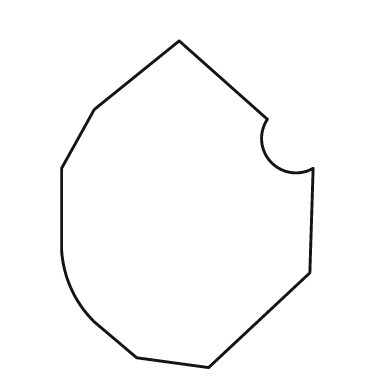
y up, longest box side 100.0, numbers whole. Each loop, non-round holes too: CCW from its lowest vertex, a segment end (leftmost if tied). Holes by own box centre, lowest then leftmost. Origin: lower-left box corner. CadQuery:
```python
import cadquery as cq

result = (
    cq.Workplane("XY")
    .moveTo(45.0, 0.0)
    .lineTo(76.0, 29.0)
    .lineTo(77.0, 61.0)
    .threePointArc((64.0, 63.0), (63.0, 76.0))
    .lineTo(36.0, 100.0)
    .lineTo(10.0, 79.0)
    .lineTo(0.0, 61.0)
    .lineTo(0.0, 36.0)
    .threePointArc((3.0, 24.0), (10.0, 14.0))
    .lineTo(23.0, 3.0)
    .close()
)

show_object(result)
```